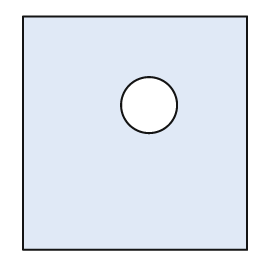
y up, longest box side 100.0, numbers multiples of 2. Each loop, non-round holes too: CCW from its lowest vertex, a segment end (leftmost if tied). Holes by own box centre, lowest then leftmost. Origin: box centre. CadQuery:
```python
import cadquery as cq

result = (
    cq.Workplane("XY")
    .moveTo(-48.0, -50.0)
    .lineTo(48.0, -50.0)
    .lineTo(48.0, 50.0)
    .lineTo(-48.0, 50.0)
    .close()
    .moveTo(6.0, 12.0)
    .circle(12.0)
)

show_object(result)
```